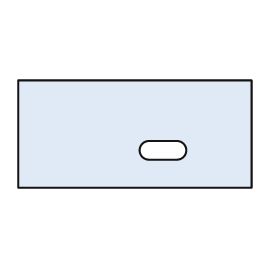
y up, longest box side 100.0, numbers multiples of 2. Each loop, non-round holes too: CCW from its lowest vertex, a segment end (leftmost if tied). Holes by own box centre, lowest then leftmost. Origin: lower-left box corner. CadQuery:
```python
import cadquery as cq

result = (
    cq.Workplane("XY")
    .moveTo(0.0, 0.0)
    .lineTo(100.0, 0.0)
    .lineTo(100.0, 46.0)
    .lineTo(0.0, 46.0)
    .close()
    .moveTo(56.0, 12.0)
    .lineTo(68.0, 12.0)
    .threePointArc((72.0, 16.0), (68.0, 20.0))
    .lineTo(56.0, 20.0)
    .threePointArc((52.0, 16.0), (56.0, 12.0))
    .close()
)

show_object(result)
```